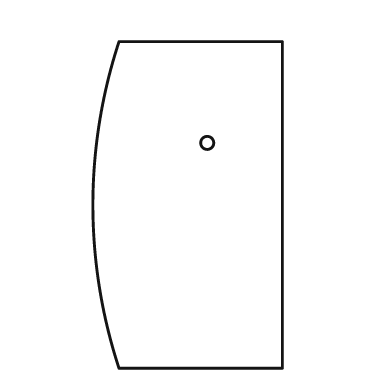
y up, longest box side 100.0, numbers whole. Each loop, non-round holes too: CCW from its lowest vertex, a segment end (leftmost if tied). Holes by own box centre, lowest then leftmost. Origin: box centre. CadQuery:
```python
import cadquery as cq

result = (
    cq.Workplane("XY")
    .moveTo(-21.0, -50.0)
    .lineTo(29.0, -50.0)
    .lineTo(29.0, 50.0)
    .lineTo(-21.0, 50.0)
    .threePointArc((-29.0, 0.0), (-21.0, -50.0))
    .close()
    .moveTo(6.0, 19.0)
    .circle(2.0)
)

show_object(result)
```